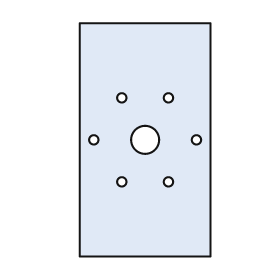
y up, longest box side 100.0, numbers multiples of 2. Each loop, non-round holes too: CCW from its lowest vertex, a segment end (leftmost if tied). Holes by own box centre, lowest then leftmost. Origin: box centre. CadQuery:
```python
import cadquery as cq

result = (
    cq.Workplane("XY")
    .moveTo(-28.0, -50.0)
    .lineTo(28.0, -50.0)
    .lineTo(28.0, 50.0)
    .lineTo(-28.0, 50.0)
    .close()
    .moveTo(-10.0, -18.0)
    .circle(2.0)
    .moveTo(10.0, -18.0)
    .circle(2.0)
    .moveTo(-22.0, 0.0)
    .circle(2.0)
    .moveTo(0.0, 0.0)
    .circle(6.0)
    .moveTo(22.0, 0.0)
    .circle(2.0)
    .moveTo(-10.0, 18.0)
    .circle(2.0)
    .moveTo(10.0, 18.0)
    .circle(2.0)
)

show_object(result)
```